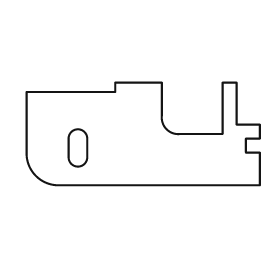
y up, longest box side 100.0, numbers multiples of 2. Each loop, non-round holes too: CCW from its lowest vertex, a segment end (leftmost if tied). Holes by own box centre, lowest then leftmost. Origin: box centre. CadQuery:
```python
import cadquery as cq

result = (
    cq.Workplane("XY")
    .moveTo(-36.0, -22.0)
    .lineTo(50.0, -22.0)
    .lineTo(50.0, -8.0)
    .lineTo(44.0, -8.0)
    .lineTo(44.0, -2.0)
    .lineTo(50.0, -2.0)
    .lineTo(50.0, 4.0)
    .lineTo(40.0, 4.0)
    .lineTo(40.0, 22.0)
    .lineTo(34.0, 22.0)
    .lineTo(34.0, 0.0)
    .lineTo(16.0, 0.0)
    .threePointArc((10.0, 2.0), (8.0, 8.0))
    .lineTo(8.0, 22.0)
    .lineTo(-12.0, 22.0)
    .lineTo(-12.0, 18.0)
    .lineTo(-50.0, 18.0)
    .lineTo(-50.0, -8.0)
    .threePointArc((-46.0, -18.0), (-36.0, -22.0))
    .close()
    .moveTo(-32.0, -10.0)
    .threePointArc((-28.0, -14.0), (-24.0, -10.0))
    .lineTo(-24.0, -2.0)
    .threePointArc((-28.0, 2.0), (-32.0, -2.0))
    .close()
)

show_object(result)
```